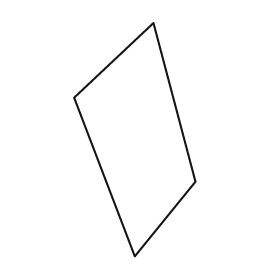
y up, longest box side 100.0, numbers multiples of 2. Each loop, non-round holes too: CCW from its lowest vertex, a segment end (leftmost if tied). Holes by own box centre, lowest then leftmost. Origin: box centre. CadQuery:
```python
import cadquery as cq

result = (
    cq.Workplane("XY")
    .moveTo(0.0, -50.0)
    .lineTo(26.0, -18.0)
    .lineTo(8.0, 50.0)
    .lineTo(-26.0, 18.0)
    .close()
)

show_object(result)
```